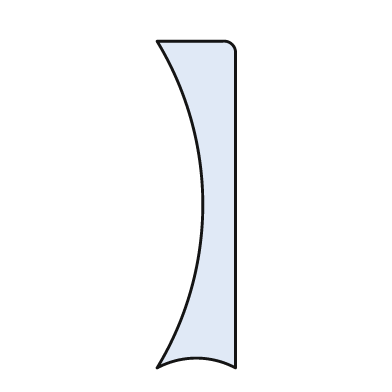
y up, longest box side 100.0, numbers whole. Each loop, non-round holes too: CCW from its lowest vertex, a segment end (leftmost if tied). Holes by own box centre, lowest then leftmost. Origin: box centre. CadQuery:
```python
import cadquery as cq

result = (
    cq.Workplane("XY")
    .moveTo(-12.0, -50.0)
    .threePointArc((0.0, -47.0), (12.0, -50.0))
    .lineTo(12.0, 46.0)
    .threePointArc((11.0, 49.0), (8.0, 50.0))
    .lineTo(-12.0, 50.0)
    .threePointArc((2.0, 0.0), (-12.0, -50.0))
    .close()
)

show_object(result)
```